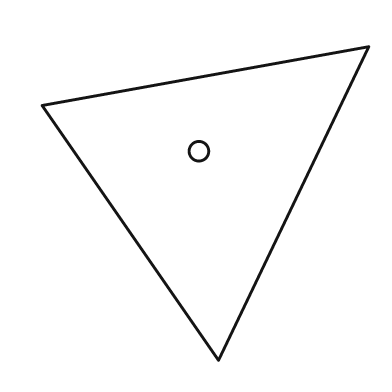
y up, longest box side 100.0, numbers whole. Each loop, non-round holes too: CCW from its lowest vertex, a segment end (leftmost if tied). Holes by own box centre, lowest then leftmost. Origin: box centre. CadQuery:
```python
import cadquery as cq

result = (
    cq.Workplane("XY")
    .moveTo(4.0, -48.0)
    .lineTo(50.0, 48.0)
    .lineTo(-50.0, 30.0)
    .close()
    .moveTo(-2.0, 16.0)
    .circle(3.0)
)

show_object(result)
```